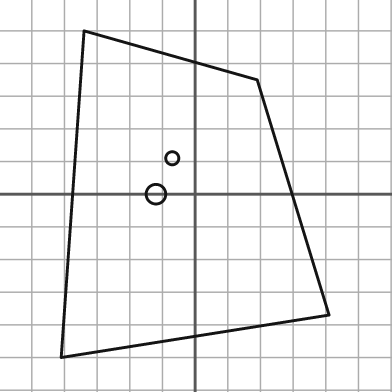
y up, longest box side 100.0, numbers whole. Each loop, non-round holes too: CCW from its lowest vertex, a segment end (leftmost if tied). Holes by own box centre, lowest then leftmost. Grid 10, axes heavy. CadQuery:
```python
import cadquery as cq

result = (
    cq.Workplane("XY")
    .moveTo(-41.0, -50.0)
    .lineTo(41.0, -37.0)
    .lineTo(19.0, 35.0)
    .lineTo(-34.0, 50.0)
    .close()
    .moveTo(-12.0, 0.0)
    .circle(3.0)
    .moveTo(-7.0, 11.0)
    .circle(2.0)
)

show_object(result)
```